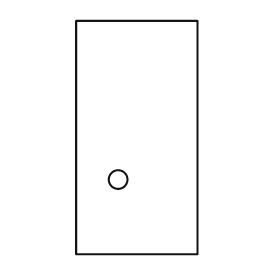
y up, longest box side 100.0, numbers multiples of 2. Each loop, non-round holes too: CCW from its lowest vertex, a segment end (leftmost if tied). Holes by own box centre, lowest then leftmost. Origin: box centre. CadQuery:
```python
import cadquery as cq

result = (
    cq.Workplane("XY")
    .moveTo(-26.0, -50.0)
    .lineTo(26.0, -50.0)
    .lineTo(26.0, 50.0)
    .lineTo(-26.0, 50.0)
    .close()
    .moveTo(-8.0, -18.0)
    .circle(4.0)
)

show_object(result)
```